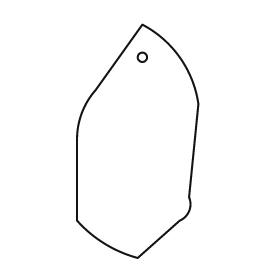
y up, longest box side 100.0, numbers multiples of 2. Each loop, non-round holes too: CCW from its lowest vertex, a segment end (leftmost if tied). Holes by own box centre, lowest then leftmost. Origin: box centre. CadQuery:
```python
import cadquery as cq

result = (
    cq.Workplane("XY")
    .moveTo(0.0, -50.0)
    .lineTo(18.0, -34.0)
    .threePointArc((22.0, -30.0), (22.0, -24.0))
    .lineTo(26.0, 16.0)
    .threePointArc((18.0, 36.0), (2.0, 50.0))
    .lineTo(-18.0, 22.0)
    .threePointArc((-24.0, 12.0), (-26.0, 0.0))
    .lineTo(-26.0, -34.0)
    .threePointArc((-14.0, -44.0), (0.0, -50.0))
    .close()
    .moveTo(2.0, 36.0)
    .circle(2.0)
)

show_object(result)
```